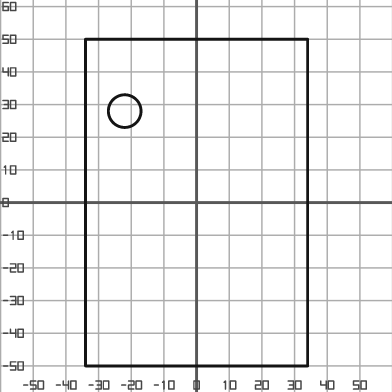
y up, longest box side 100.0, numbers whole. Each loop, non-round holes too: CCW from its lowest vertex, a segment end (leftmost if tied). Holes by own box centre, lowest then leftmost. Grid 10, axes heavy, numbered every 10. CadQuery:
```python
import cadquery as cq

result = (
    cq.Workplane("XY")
    .moveTo(-34.0, -50.0)
    .lineTo(34.0, -50.0)
    .lineTo(34.0, 50.0)
    .lineTo(-34.0, 50.0)
    .close()
    .moveTo(-22.0, 28.0)
    .circle(5.0)
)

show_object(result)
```